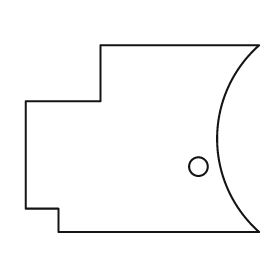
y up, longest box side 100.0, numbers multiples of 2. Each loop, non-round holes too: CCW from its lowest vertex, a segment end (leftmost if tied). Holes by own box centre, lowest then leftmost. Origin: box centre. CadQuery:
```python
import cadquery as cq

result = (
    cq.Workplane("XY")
    .moveTo(-36.0, -40.0)
    .lineTo(50.0, -40.0)
    .threePointArc((32.0, 0.0), (50.0, 40.0))
    .lineTo(-18.0, 40.0)
    .lineTo(-18.0, 16.0)
    .lineTo(-50.0, 16.0)
    .lineTo(-50.0, -30.0)
    .lineTo(-36.0, -30.0)
    .close()
    .moveTo(24.0, -12.0)
    .circle(4.0)
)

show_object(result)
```